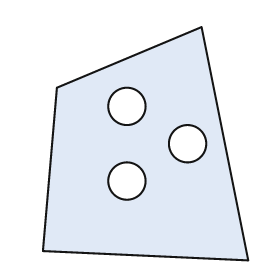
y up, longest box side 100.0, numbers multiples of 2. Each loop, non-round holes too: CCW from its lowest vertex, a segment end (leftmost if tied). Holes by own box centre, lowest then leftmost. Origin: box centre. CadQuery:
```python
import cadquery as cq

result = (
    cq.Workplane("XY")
    .moveTo(44.0, -50.0)
    .lineTo(24.0, 50.0)
    .lineTo(-38.0, 24.0)
    .lineTo(-44.0, -46.0)
    .close()
    .moveTo(-8.0, -16.0)
    .circle(8.0)
    .moveTo(18.0, 0.0)
    .circle(8.0)
    .moveTo(-8.0, 16.0)
    .circle(8.0)
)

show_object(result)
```